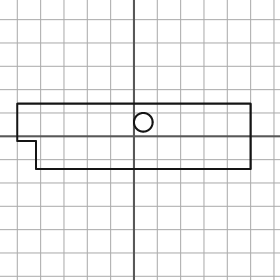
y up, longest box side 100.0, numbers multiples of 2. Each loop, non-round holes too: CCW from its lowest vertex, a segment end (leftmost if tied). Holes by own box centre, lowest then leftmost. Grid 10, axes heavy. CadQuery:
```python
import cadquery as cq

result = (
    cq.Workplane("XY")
    .moveTo(-42.0, -14.0)
    .lineTo(50.0, -14.0)
    .lineTo(50.0, 14.0)
    .lineTo(-50.0, 14.0)
    .lineTo(-50.0, -2.0)
    .lineTo(-42.0, -2.0)
    .close()
    .moveTo(4.0, 6.0)
    .circle(4.0)
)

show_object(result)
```